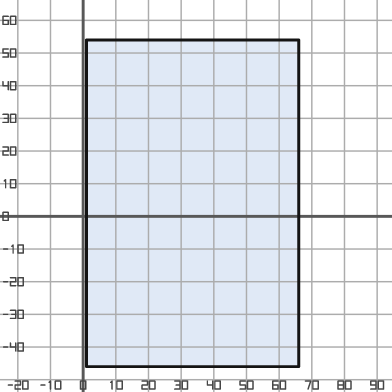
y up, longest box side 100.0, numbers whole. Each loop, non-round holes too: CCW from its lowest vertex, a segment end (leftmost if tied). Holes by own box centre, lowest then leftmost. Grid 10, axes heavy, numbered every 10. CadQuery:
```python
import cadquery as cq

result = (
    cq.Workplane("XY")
    .moveTo(1.0, -46.0)
    .lineTo(66.0, -46.0)
    .lineTo(66.0, 54.0)
    .lineTo(1.0, 54.0)
    .close()
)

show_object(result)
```